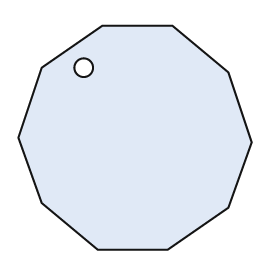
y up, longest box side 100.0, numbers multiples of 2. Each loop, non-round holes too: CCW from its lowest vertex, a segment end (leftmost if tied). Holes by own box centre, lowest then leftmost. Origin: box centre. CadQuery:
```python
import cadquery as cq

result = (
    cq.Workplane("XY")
    .moveTo(-16.0, -48.0)
    .lineTo(14.0, -48.0)
    .lineTo(40.0, -30.0)
    .lineTo(50.0, -2.0)
    .lineTo(40.0, 28.0)
    .lineTo(16.0, 48.0)
    .lineTo(-14.0, 48.0)
    .lineTo(-40.0, 30.0)
    .lineTo(-50.0, 0.0)
    .lineTo(-40.0, -28.0)
    .close()
    .moveTo(-22.0, 30.0)
    .circle(4.0)
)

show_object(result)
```